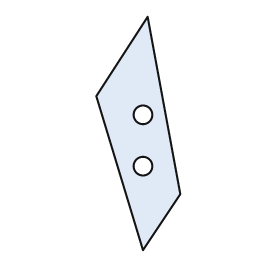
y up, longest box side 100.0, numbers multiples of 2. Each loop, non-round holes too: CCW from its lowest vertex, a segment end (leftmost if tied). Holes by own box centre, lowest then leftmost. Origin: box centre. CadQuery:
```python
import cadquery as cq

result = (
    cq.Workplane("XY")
    .moveTo(2.0, -50.0)
    .lineTo(18.0, -26.0)
    .lineTo(4.0, 50.0)
    .lineTo(-18.0, 16.0)
    .close()
    .moveTo(2.0, -14.0)
    .circle(4.0)
    .moveTo(2.0, 8.0)
    .circle(4.0)
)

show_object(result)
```